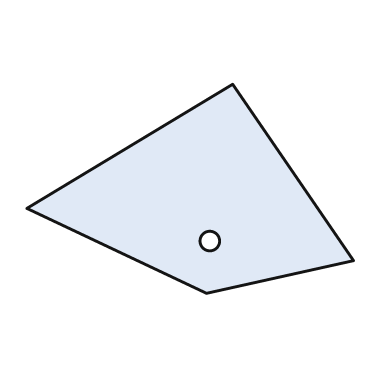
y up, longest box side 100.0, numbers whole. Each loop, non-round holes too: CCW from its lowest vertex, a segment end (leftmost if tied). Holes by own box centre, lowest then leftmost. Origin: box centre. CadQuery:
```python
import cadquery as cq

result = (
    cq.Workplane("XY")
    .moveTo(5.0, -32.0)
    .lineTo(50.0, -22.0)
    .lineTo(13.0, 32.0)
    .lineTo(-50.0, -6.0)
    .close()
    .moveTo(6.0, -16.0)
    .circle(3.0)
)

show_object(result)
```